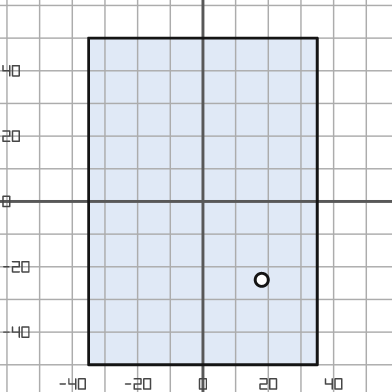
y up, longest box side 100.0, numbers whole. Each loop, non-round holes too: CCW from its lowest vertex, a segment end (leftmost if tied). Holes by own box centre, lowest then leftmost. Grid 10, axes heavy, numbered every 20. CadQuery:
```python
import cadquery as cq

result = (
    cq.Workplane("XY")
    .moveTo(-35.0, -50.0)
    .lineTo(35.0, -50.0)
    .lineTo(35.0, 50.0)
    .lineTo(-35.0, 50.0)
    .close()
    .moveTo(18.0, -24.0)
    .circle(2.0)
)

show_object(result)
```